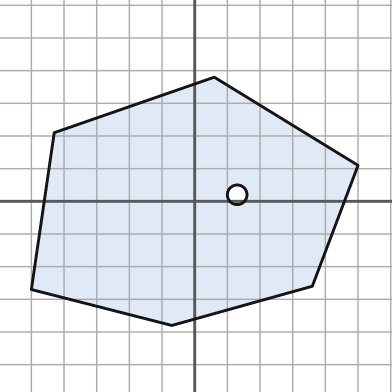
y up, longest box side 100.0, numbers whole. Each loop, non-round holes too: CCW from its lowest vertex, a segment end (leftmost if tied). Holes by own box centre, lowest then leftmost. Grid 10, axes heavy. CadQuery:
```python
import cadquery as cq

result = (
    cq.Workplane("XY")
    .moveTo(-7.0, -38.0)
    .lineTo(36.0, -26.0)
    .lineTo(50.0, 11.0)
    .lineTo(6.0, 38.0)
    .lineTo(-43.0, 21.0)
    .lineTo(-50.0, -27.0)
    .close()
    .moveTo(13.0, 2.0)
    .circle(3.0)
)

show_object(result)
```